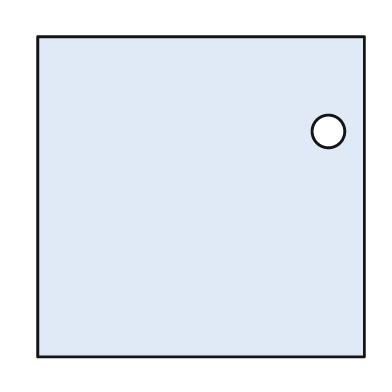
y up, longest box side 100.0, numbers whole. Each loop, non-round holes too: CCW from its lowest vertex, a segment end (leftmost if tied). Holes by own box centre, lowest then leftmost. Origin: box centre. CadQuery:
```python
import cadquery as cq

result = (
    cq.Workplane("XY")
    .moveTo(-50.0, -49.0)
    .lineTo(50.0, -49.0)
    .lineTo(50.0, 49.0)
    .lineTo(-50.0, 49.0)
    .close()
    .moveTo(39.0, 20.0)
    .circle(5.0)
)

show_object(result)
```